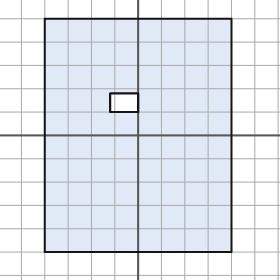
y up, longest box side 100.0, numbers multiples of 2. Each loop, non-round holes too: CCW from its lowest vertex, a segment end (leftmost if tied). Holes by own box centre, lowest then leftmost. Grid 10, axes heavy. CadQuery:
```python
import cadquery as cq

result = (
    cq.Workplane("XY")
    .moveTo(-40.0, -50.0)
    .lineTo(40.0, -50.0)
    .lineTo(40.0, 50.0)
    .lineTo(-40.0, 50.0)
    .close()
    .moveTo(-12.0, 10.0)
    .lineTo(0.0, 10.0)
    .lineTo(0.0, 18.0)
    .lineTo(-12.0, 18.0)
    .close()
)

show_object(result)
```